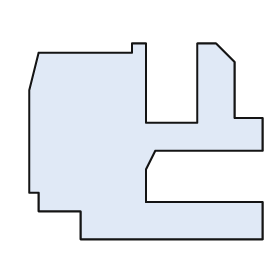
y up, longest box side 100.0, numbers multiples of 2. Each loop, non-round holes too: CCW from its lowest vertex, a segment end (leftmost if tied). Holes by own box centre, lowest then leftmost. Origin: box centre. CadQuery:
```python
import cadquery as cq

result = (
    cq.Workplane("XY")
    .moveTo(-28.0, -42.0)
    .lineTo(50.0, -42.0)
    .lineTo(50.0, -26.0)
    .lineTo(0.0, -26.0)
    .lineTo(0.0, -12.0)
    .lineTo(4.0, -4.0)
    .lineTo(50.0, -4.0)
    .lineTo(50.0, 10.0)
    .lineTo(38.0, 10.0)
    .lineTo(38.0, 34.0)
    .lineTo(30.0, 42.0)
    .lineTo(22.0, 42.0)
    .lineTo(22.0, 8.0)
    .lineTo(0.0, 8.0)
    .lineTo(0.0, 42.0)
    .lineTo(-6.0, 42.0)
    .lineTo(-6.0, 38.0)
    .lineTo(-46.0, 38.0)
    .lineTo(-50.0, 22.0)
    .lineTo(-50.0, -22.0)
    .lineTo(-46.0, -22.0)
    .lineTo(-46.0, -30.0)
    .lineTo(-28.0, -30.0)
    .close()
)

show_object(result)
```